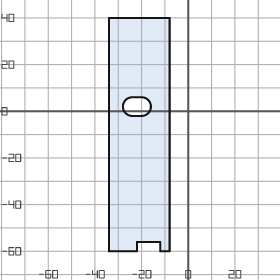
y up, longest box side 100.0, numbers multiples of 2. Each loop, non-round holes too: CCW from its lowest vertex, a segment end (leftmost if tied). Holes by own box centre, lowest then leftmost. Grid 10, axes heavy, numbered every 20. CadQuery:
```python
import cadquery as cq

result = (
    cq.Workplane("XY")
    .moveTo(-34.0, -60.0)
    .lineTo(-22.0, -60.0)
    .lineTo(-22.0, -56.0)
    .lineTo(-12.0, -56.0)
    .lineTo(-12.0, -60.0)
    .lineTo(-8.0, -60.0)
    .lineTo(-8.0, 40.0)
    .lineTo(-34.0, 40.0)
    .close()
    .moveTo(-24.0, -2.0)
    .lineTo(-20.0, -2.0)
    .threePointArc((-16.0, 2.0), (-20.0, 6.0))
    .lineTo(-24.0, 6.0)
    .threePointArc((-28.0, 2.0), (-24.0, -2.0))
    .close()
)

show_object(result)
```